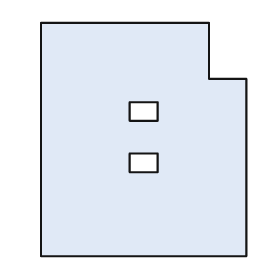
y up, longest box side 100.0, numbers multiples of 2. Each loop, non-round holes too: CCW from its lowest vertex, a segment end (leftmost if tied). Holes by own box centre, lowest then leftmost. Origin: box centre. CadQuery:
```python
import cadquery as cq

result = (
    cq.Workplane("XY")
    .moveTo(-44.0, -50.0)
    .lineTo(44.0, -50.0)
    .lineTo(44.0, 26.0)
    .lineTo(28.0, 26.0)
    .lineTo(28.0, 50.0)
    .lineTo(-44.0, 50.0)
    .close()
    .moveTo(-6.0, -14.0)
    .lineTo(6.0, -14.0)
    .lineTo(6.0, -6.0)
    .lineTo(-6.0, -6.0)
    .close()
    .moveTo(-6.0, 8.0)
    .lineTo(6.0, 8.0)
    .lineTo(6.0, 16.0)
    .lineTo(-6.0, 16.0)
    .close()
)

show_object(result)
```